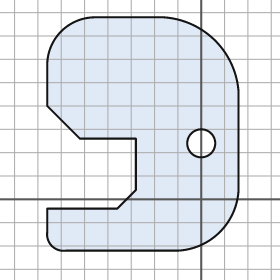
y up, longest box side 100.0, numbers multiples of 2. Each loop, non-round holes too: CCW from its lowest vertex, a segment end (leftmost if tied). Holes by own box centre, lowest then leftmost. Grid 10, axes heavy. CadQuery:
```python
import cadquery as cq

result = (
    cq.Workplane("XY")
    .moveTo(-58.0, -22.0)
    .lineTo(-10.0, -22.0)
    .threePointArc((8.0, -14.0), (16.0, 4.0))
    .lineTo(16.0, 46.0)
    .threePointArc((6.0, 68.0), (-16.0, 78.0))
    .lineTo(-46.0, 78.0)
    .threePointArc((-60.0, 72.0), (-66.0, 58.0))
    .lineTo(-66.0, 40.0)
    .lineTo(-52.0, 26.0)
    .lineTo(-28.0, 26.0)
    .lineTo(-28.0, 4.0)
    .lineTo(-36.0, -4.0)
    .lineTo(-66.0, -4.0)
    .lineTo(-66.0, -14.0)
    .threePointArc((-64.0, -20.0), (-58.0, -22.0))
    .close()
    .moveTo(0.0, 24.0)
    .circle(6.0)
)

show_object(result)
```